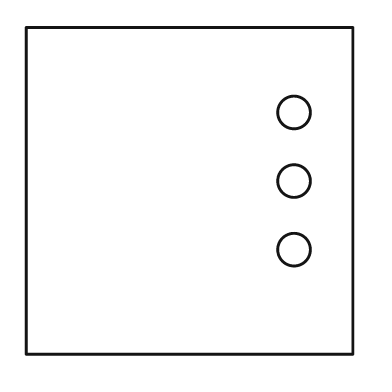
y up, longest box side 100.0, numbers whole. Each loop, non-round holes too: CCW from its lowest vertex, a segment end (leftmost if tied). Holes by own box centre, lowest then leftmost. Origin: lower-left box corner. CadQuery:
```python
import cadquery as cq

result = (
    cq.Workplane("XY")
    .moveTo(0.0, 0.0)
    .lineTo(100.0, 0.0)
    .lineTo(100.0, 100.0)
    .lineTo(0.0, 100.0)
    .close()
    .moveTo(82.0, 32.0)
    .circle(5.0)
    .moveTo(82.0, 53.0)
    .circle(5.0)
    .moveTo(82.0, 74.0)
    .circle(5.0)
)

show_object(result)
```